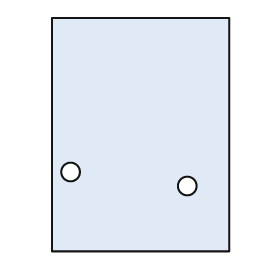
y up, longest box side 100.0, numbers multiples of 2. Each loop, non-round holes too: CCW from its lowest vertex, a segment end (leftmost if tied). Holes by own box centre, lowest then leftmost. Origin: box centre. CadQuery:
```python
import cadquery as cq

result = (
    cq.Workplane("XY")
    .moveTo(-38.0, -50.0)
    .lineTo(38.0, -50.0)
    .lineTo(38.0, 50.0)
    .lineTo(-38.0, 50.0)
    .close()
    .moveTo(20.0, -22.0)
    .circle(4.0)
    .moveTo(-30.0, -16.0)
    .circle(4.0)
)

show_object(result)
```